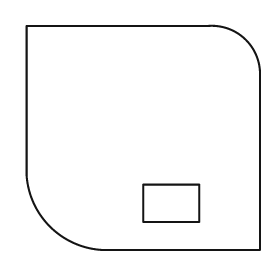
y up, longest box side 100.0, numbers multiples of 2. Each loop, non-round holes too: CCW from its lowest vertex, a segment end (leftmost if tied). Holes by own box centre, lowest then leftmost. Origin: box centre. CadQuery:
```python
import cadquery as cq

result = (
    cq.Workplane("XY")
    .moveTo(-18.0, -48.0)
    .lineTo(50.0, -48.0)
    .lineTo(50.0, 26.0)
    .threePointArc((44.0, 42.0), (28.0, 48.0))
    .lineTo(-50.0, 48.0)
    .lineTo(-50.0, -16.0)
    .threePointArc((-40.0, -38.0), (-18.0, -48.0))
    .close()
    .moveTo(0.0, -36.0)
    .lineTo(24.0, -36.0)
    .lineTo(24.0, -20.0)
    .lineTo(0.0, -20.0)
    .close()
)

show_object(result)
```